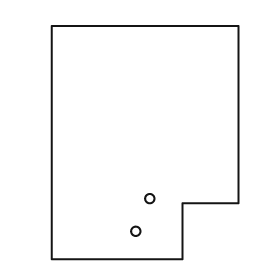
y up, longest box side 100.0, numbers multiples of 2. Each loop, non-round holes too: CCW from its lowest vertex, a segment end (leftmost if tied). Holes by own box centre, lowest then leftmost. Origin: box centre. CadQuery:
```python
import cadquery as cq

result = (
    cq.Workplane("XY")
    .moveTo(-40.0, -50.0)
    .lineTo(16.0, -50.0)
    .lineTo(16.0, -26.0)
    .lineTo(40.0, -26.0)
    .lineTo(40.0, 50.0)
    .lineTo(-40.0, 50.0)
    .close()
    .moveTo(-4.0, -38.0)
    .circle(2.0)
    .moveTo(2.0, -24.0)
    .circle(2.0)
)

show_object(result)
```